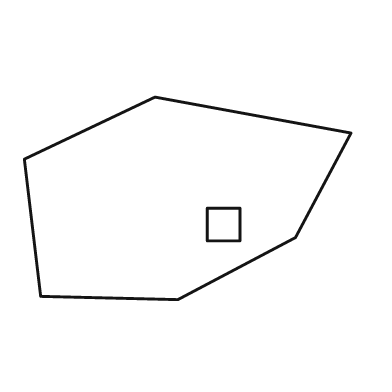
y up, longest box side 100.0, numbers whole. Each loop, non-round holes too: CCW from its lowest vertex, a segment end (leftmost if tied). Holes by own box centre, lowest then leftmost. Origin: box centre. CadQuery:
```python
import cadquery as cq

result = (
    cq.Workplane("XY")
    .moveTo(-3.0, -31.0)
    .lineTo(33.0, -12.0)
    .lineTo(50.0, 20.0)
    .lineTo(-10.0, 31.0)
    .lineTo(-50.0, 12.0)
    .lineTo(-45.0, -30.0)
    .close()
    .moveTo(6.0, -13.0)
    .lineTo(16.0, -13.0)
    .lineTo(16.0, -3.0)
    .lineTo(6.0, -3.0)
    .close()
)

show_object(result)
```